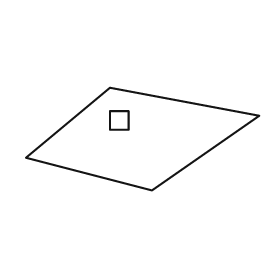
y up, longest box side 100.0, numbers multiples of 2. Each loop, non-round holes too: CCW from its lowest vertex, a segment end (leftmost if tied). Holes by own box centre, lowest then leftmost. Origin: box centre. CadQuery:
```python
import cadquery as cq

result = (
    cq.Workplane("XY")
    .moveTo(4.0, -22.0)
    .lineTo(50.0, 10.0)
    .lineTo(-14.0, 22.0)
    .lineTo(-50.0, -8.0)
    .close()
    .moveTo(-14.0, 4.0)
    .lineTo(-6.0, 4.0)
    .lineTo(-6.0, 12.0)
    .lineTo(-14.0, 12.0)
    .close()
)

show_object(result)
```